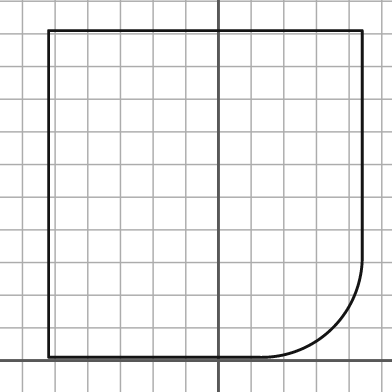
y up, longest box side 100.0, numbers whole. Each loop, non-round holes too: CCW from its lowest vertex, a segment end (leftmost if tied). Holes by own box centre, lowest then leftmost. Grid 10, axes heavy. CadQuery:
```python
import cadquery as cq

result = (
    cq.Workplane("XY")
    .moveTo(-52.0, 1.0)
    .lineTo(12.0, 1.0)
    .threePointArc((35.0, 10.0), (44.0, 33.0))
    .lineTo(44.0, 101.0)
    .lineTo(-52.0, 101.0)
    .close()
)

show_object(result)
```